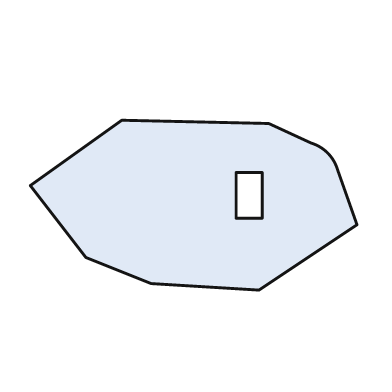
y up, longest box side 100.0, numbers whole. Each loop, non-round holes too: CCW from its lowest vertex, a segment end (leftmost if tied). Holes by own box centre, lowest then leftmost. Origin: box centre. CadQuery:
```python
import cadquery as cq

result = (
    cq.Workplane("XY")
    .moveTo(20.0, -26.0)
    .lineTo(50.0, -6.0)
    .lineTo(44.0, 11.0)
    .threePointArc((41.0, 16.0), (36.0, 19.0))
    .lineTo(23.0, 25.0)
    .lineTo(-22.0, 26.0)
    .lineTo(-50.0, 6.0)
    .lineTo(-33.0, -16.0)
    .lineTo(-13.0, -24.0)
    .close()
    .moveTo(13.0, -4.0)
    .lineTo(21.0, -4.0)
    .lineTo(21.0, 10.0)
    .lineTo(13.0, 10.0)
    .close()
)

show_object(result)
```